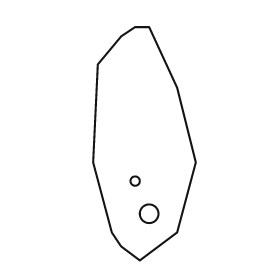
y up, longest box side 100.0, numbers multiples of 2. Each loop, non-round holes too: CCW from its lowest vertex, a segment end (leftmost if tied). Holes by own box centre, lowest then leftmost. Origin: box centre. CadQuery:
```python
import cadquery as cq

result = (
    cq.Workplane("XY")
    .moveTo(-2.0, -50.0)
    .lineTo(14.0, -38.0)
    .lineTo(22.0, -8.0)
    .lineTo(14.0, 24.0)
    .lineTo(2.0, 50.0)
    .lineTo(-4.0, 50.0)
    .lineTo(-10.0, 46.0)
    .lineTo(-20.0, 34.0)
    .lineTo(-22.0, -8.0)
    .lineTo(-14.0, -38.0)
    .lineTo(-10.0, -44.0)
    .close()
    .moveTo(2.0, -30.0)
    .circle(4.0)
    .moveTo(-4.0, -16.0)
    .circle(2.0)
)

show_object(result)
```